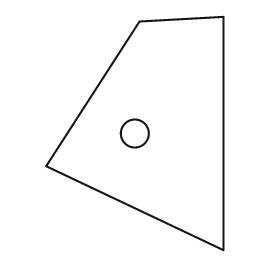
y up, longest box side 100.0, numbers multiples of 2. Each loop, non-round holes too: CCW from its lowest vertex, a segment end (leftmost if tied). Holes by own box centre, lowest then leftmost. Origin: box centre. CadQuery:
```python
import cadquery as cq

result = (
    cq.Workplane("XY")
    .moveTo(38.0, -50.0)
    .lineTo(38.0, 50.0)
    .lineTo(2.0, 48.0)
    .lineTo(-38.0, -14.0)
    .close()
    .moveTo(0.0, 0.0)
    .circle(6.0)
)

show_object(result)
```